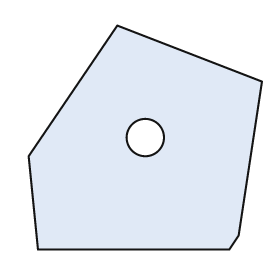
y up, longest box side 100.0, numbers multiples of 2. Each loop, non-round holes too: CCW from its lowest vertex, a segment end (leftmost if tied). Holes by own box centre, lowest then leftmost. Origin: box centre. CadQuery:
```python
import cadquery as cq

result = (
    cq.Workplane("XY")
    .moveTo(-46.0, -48.0)
    .lineTo(36.0, -48.0)
    .lineTo(40.0, -42.0)
    .lineTo(50.0, 24.0)
    .lineTo(-12.0, 48.0)
    .lineTo(-50.0, -8.0)
    .close()
    .moveTo(0.0, 0.0)
    .circle(8.0)
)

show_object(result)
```